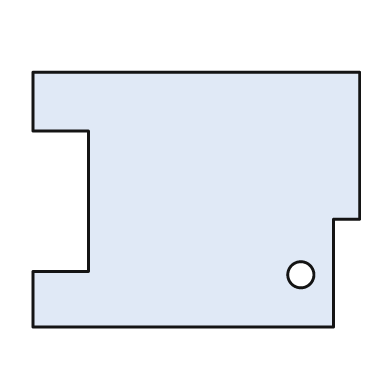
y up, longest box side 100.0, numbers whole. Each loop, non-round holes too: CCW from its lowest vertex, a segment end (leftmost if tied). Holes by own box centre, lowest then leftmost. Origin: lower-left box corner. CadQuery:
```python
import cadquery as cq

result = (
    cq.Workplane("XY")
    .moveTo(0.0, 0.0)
    .lineTo(92.0, 0.0)
    .lineTo(92.0, 33.0)
    .lineTo(100.0, 33.0)
    .lineTo(100.0, 78.0)
    .lineTo(0.0, 78.0)
    .lineTo(0.0, 60.0)
    .lineTo(17.0, 60.0)
    .lineTo(17.0, 17.0)
    .lineTo(0.0, 17.0)
    .close()
    .moveTo(82.0, 16.0)
    .circle(4.0)
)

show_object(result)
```